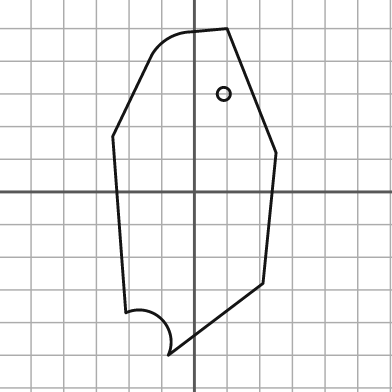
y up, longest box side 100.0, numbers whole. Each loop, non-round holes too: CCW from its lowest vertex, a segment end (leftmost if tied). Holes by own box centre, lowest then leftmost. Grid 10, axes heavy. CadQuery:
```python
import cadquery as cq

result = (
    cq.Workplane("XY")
    .moveTo(-8.0, -50.0)
    .lineTo(21.0, -28.0)
    .lineTo(25.0, 12.0)
    .lineTo(10.0, 50.0)
    .lineTo(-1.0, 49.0)
    .threePointArc((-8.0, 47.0), (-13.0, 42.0))
    .lineTo(-25.0, 17.0)
    .lineTo(-21.0, -37.0)
    .threePointArc((-10.0, -39.0), (-8.0, -50.0))
    .close()
    .moveTo(9.0, 30.0)
    .circle(2.0)
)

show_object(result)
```